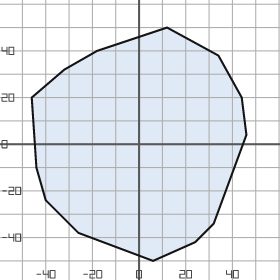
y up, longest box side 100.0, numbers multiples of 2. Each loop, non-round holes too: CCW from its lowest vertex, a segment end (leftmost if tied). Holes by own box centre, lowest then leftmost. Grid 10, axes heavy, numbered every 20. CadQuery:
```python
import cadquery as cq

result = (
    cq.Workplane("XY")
    .moveTo(6.0, -50.0)
    .lineTo(24.0, -42.0)
    .lineTo(32.0, -34.0)
    .lineTo(46.0, 4.0)
    .lineTo(44.0, 20.0)
    .lineTo(34.0, 38.0)
    .lineTo(12.0, 50.0)
    .lineTo(-18.0, 40.0)
    .lineTo(-32.0, 32.0)
    .lineTo(-46.0, 20.0)
    .lineTo(-44.0, -10.0)
    .lineTo(-40.0, -24.0)
    .lineTo(-26.0, -38.0)
    .close()
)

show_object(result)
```